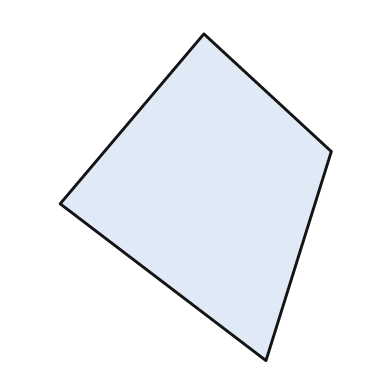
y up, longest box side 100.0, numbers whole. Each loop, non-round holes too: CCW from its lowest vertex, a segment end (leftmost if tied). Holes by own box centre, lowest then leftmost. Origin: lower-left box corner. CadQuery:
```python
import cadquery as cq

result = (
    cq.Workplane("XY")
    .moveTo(63.0, 0.0)
    .lineTo(83.0, 64.0)
    .lineTo(44.0, 100.0)
    .lineTo(0.0, 48.0)
    .close()
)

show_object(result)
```